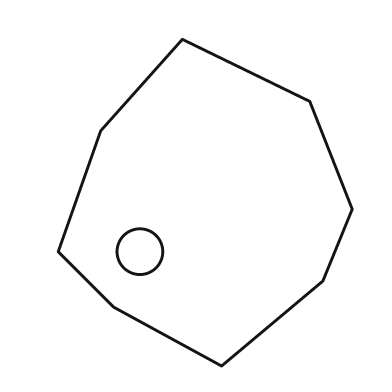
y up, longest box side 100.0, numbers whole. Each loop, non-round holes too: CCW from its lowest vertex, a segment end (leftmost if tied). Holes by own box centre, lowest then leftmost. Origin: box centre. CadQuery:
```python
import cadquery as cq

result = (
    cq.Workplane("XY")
    .moveTo(5.0, -50.0)
    .lineTo(36.0, -24.0)
    .lineTo(45.0, -2.0)
    .lineTo(32.0, 31.0)
    .lineTo(-7.0, 50.0)
    .lineTo(-32.0, 22.0)
    .lineTo(-45.0, -15.0)
    .lineTo(-28.0, -32.0)
    .close()
    .moveTo(-20.0, -15.0)
    .circle(7.0)
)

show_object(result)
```